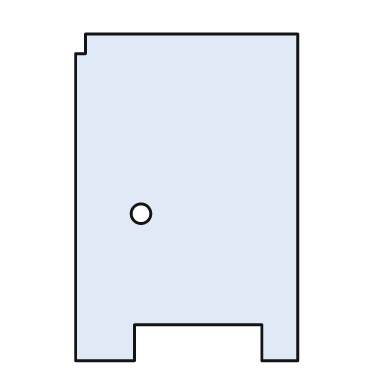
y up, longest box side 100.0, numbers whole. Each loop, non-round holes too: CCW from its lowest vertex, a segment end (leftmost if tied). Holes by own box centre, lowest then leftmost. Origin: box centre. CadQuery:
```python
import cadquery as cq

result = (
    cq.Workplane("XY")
    .moveTo(-34.0, -50.0)
    .lineTo(-16.0, -50.0)
    .lineTo(-16.0, -39.0)
    .lineTo(23.0, -39.0)
    .lineTo(23.0, -50.0)
    .lineTo(34.0, -50.0)
    .lineTo(34.0, 50.0)
    .lineTo(-31.0, 50.0)
    .lineTo(-31.0, 44.0)
    .lineTo(-34.0, 44.0)
    .close()
    .moveTo(-14.0, -5.0)
    .circle(3.0)
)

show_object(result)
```